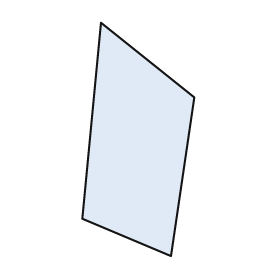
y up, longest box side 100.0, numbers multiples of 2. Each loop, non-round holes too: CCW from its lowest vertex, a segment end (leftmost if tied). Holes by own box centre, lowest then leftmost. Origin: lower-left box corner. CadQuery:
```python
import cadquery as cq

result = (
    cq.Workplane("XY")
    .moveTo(38.0, 0.0)
    .lineTo(48.0, 68.0)
    .lineTo(8.0, 100.0)
    .lineTo(0.0, 16.0)
    .close()
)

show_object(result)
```